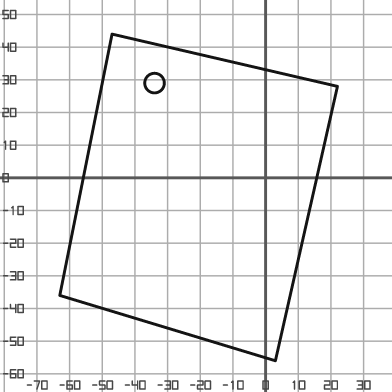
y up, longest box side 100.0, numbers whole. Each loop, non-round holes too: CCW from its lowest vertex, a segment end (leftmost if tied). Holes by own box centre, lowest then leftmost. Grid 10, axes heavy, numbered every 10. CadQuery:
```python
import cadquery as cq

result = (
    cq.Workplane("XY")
    .moveTo(3.0, -56.0)
    .lineTo(22.0, 28.0)
    .lineTo(-47.0, 44.0)
    .lineTo(-63.0, -36.0)
    .close()
    .moveTo(-34.0, 29.0)
    .circle(3.0)
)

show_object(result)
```